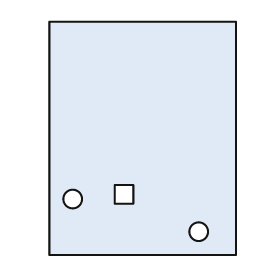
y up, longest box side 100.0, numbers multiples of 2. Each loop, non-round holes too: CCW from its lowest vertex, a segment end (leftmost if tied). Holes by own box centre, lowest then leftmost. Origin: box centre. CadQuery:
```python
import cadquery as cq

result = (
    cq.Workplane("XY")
    .moveTo(-40.0, -50.0)
    .lineTo(40.0, -50.0)
    .lineTo(40.0, 50.0)
    .lineTo(-40.0, 50.0)
    .close()
    .moveTo(24.0, -40.0)
    .circle(4.0)
    .moveTo(-30.0, -26.0)
    .circle(4.0)
    .moveTo(-12.0, -28.0)
    .lineTo(-4.0, -28.0)
    .lineTo(-4.0, -20.0)
    .lineTo(-12.0, -20.0)
    .close()
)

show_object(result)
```